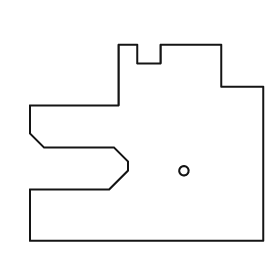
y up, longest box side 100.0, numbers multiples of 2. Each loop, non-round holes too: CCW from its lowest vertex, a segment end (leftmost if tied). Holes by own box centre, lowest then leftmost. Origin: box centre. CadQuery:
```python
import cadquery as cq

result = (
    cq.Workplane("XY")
    .moveTo(-50.0, -42.0)
    .lineTo(50.0, -42.0)
    .lineTo(50.0, 24.0)
    .lineTo(32.0, 24.0)
    .lineTo(32.0, 42.0)
    .lineTo(6.0, 42.0)
    .lineTo(6.0, 34.0)
    .lineTo(-4.0, 34.0)
    .lineTo(-4.0, 42.0)
    .lineTo(-12.0, 42.0)
    .lineTo(-12.0, 16.0)
    .lineTo(-50.0, 16.0)
    .lineTo(-50.0, 4.0)
    .lineTo(-44.0, -2.0)
    .lineTo(-14.0, -2.0)
    .lineTo(-8.0, -8.0)
    .lineTo(-8.0, -12.0)
    .lineTo(-16.0, -20.0)
    .lineTo(-50.0, -20.0)
    .close()
    .moveTo(16.0, -12.0)
    .circle(2.0)
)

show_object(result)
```